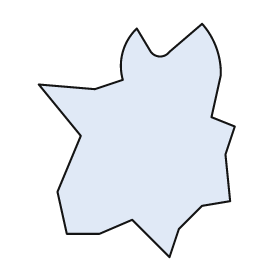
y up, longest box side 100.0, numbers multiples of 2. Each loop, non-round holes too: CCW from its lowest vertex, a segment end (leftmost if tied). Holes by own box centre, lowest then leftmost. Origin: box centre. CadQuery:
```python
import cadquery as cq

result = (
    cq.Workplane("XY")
    .moveTo(14.0, -50.0)
    .lineTo(18.0, -38.0)
    .lineTo(28.0, -28.0)
    .lineTo(40.0, -26.0)
    .lineTo(38.0, -6.0)
    .lineTo(42.0, 6.0)
    .lineTo(32.0, 10.0)
    .lineTo(36.0, 28.0)
    .threePointArc((34.0, 40.0), (28.0, 50.0))
    .lineTo(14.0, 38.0)
    .threePointArc((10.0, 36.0), (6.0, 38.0))
    .lineTo(0.0, 48.0)
    .threePointArc((-6.0, 38.0), (-6.0, 26.0))
    .lineTo(-18.0, 22.0)
    .lineTo(-42.0, 24.0)
    .lineTo(-24.0, 2.0)
    .lineTo(-34.0, -22.0)
    .lineTo(-30.0, -40.0)
    .lineTo(-16.0, -40.0)
    .lineTo(-2.0, -34.0)
    .close()
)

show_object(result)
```